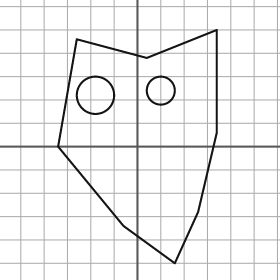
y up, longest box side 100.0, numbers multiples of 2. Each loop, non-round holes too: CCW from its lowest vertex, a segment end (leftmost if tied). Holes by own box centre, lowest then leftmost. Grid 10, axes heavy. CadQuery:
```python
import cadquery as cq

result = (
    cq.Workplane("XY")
    .moveTo(16.0, -50.0)
    .lineTo(26.0, -28.0)
    .lineTo(34.0, 6.0)
    .lineTo(34.0, 50.0)
    .lineTo(4.0, 38.0)
    .lineTo(-26.0, 46.0)
    .lineTo(-34.0, 0.0)
    .lineTo(-6.0, -34.0)
    .close()
    .moveTo(-18.0, 22.0)
    .circle(8.0)
    .moveTo(10.0, 24.0)
    .circle(6.0)
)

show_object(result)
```